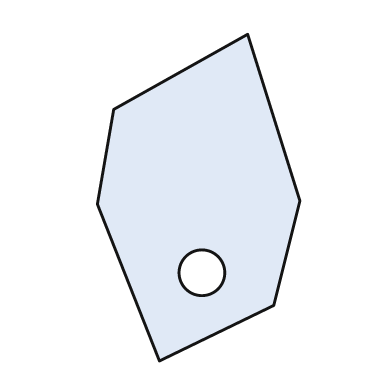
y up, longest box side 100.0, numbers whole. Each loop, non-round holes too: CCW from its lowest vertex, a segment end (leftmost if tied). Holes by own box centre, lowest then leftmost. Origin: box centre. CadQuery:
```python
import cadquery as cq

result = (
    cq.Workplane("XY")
    .moveTo(-12.0, -50.0)
    .lineTo(23.0, -33.0)
    .lineTo(31.0, -1.0)
    .lineTo(15.0, 50.0)
    .lineTo(-26.0, 27.0)
    .lineTo(-31.0, -2.0)
    .close()
    .moveTo(1.0, -23.0)
    .circle(7.0)
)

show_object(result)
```